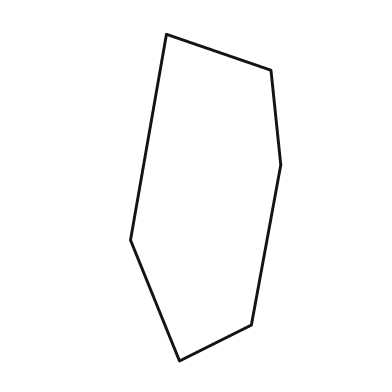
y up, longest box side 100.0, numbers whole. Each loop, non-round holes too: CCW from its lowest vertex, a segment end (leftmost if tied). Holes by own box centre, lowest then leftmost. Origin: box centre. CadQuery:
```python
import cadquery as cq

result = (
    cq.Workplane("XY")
    .moveTo(-8.0, -50.0)
    .lineTo(14.0, -39.0)
    .lineTo(23.0, 10.0)
    .lineTo(20.0, 39.0)
    .lineTo(-12.0, 50.0)
    .lineTo(-23.0, -13.0)
    .close()
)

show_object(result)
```